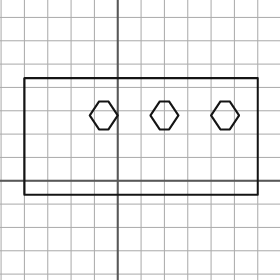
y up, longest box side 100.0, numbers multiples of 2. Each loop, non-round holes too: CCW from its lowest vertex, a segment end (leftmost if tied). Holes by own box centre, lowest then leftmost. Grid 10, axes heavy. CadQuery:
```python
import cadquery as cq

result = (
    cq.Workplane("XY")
    .moveTo(-40.0, -6.0)
    .lineTo(60.0, -6.0)
    .lineTo(60.0, 44.0)
    .lineTo(-40.0, 44.0)
    .close()
    .moveTo(-8.0, 22.0)
    .lineTo(-4.0, 22.0)
    .lineTo(0.0, 28.0)
    .lineTo(-4.0, 34.0)
    .lineTo(-8.0, 34.0)
    .lineTo(-12.0, 28.0)
    .close()
    .moveTo(18.0, 22.0)
    .lineTo(22.0, 22.0)
    .lineTo(26.0, 28.0)
    .lineTo(22.0, 34.0)
    .lineTo(18.0, 34.0)
    .lineTo(14.0, 28.0)
    .close()
    .moveTo(44.0, 22.0)
    .lineTo(48.0, 22.0)
    .lineTo(52.0, 28.0)
    .lineTo(48.0, 34.0)
    .lineTo(44.0, 34.0)
    .lineTo(40.0, 28.0)
    .close()
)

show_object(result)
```